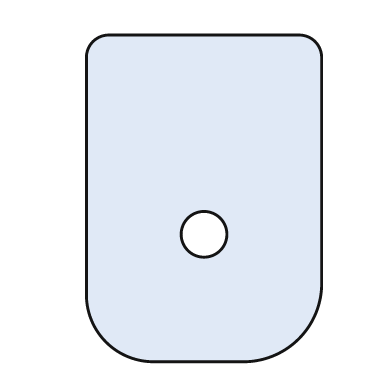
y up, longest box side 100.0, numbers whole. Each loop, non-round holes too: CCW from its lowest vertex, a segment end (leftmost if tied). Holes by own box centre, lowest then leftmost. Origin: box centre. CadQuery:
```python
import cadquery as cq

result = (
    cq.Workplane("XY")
    .moveTo(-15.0, -50.0)
    .lineTo(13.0, -50.0)
    .threePointArc((29.0, -43.0), (36.0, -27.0))
    .lineTo(36.0, 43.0)
    .threePointArc((34.0, 48.0), (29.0, 50.0))
    .lineTo(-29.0, 50.0)
    .threePointArc((-34.0, 48.0), (-36.0, 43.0))
    .lineTo(-36.0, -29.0)
    .threePointArc((-30.0, -44.0), (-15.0, -50.0))
    .close()
    .moveTo(0.0, -11.0)
    .circle(7.0)
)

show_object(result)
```